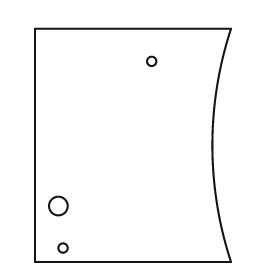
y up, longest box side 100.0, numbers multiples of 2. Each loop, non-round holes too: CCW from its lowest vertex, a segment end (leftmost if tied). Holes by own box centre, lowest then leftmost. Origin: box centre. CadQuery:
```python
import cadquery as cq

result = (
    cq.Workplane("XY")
    .moveTo(-42.0, -50.0)
    .lineTo(42.0, -50.0)
    .threePointArc((34.0, 0.0), (42.0, 50.0))
    .lineTo(-42.0, 50.0)
    .close()
    .moveTo(-30.0, -44.0)
    .circle(2.0)
    .moveTo(-32.0, -26.0)
    .circle(4.0)
    .moveTo(8.0, 36.0)
    .circle(2.0)
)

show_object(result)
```